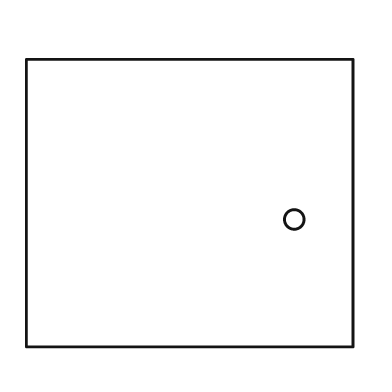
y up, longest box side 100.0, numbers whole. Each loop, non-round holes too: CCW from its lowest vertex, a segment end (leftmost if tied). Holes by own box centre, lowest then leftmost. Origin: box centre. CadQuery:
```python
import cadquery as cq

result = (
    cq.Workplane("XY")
    .moveTo(-50.0, -44.0)
    .lineTo(50.0, -44.0)
    .lineTo(50.0, 44.0)
    .lineTo(-50.0, 44.0)
    .close()
    .moveTo(32.0, -5.0)
    .circle(3.0)
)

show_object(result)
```